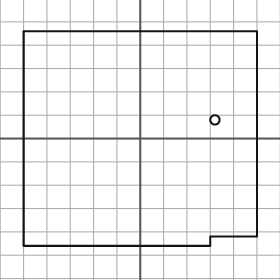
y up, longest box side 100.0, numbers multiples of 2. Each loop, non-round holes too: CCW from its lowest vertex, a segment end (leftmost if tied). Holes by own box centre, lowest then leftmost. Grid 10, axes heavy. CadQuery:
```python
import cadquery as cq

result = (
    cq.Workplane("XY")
    .moveTo(-50.0, -46.0)
    .lineTo(30.0, -46.0)
    .lineTo(30.0, -42.0)
    .lineTo(50.0, -42.0)
    .lineTo(50.0, 46.0)
    .lineTo(-50.0, 46.0)
    .close()
    .moveTo(32.0, 8.0)
    .circle(2.0)
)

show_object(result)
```